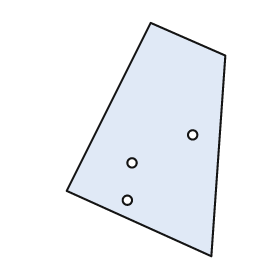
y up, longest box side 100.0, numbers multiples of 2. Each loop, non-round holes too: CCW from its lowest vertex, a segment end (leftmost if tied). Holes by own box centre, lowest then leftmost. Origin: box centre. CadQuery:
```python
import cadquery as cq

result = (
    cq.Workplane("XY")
    .moveTo(28.0, -50.0)
    .lineTo(34.0, 36.0)
    .lineTo(2.0, 50.0)
    .lineTo(-34.0, -22.0)
    .close()
    .moveTo(-8.0, -26.0)
    .circle(2.0)
    .moveTo(-6.0, -10.0)
    .circle(2.0)
    .moveTo(20.0, 2.0)
    .circle(2.0)
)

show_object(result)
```